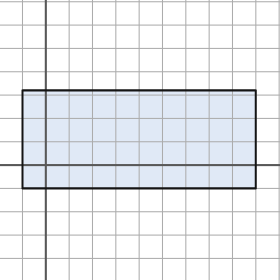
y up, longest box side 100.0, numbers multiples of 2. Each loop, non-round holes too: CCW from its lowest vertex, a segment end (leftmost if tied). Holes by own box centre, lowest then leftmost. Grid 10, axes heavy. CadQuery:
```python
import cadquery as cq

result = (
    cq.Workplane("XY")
    .moveTo(-10.0, -10.0)
    .lineTo(90.0, -10.0)
    .lineTo(90.0, 32.0)
    .lineTo(-10.0, 32.0)
    .close()
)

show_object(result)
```